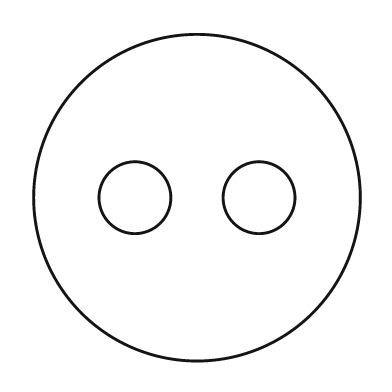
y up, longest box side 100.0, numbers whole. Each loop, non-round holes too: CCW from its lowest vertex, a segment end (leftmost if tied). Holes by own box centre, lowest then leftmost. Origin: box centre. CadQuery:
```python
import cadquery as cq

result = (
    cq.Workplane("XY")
    .moveTo(0.0, 0.0)
    .circle(50.0)
    .moveTo(-19.0, 0.0)
    .circle(11.0)
    .moveTo(19.0, 0.0)
    .circle(11.0)
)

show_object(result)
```